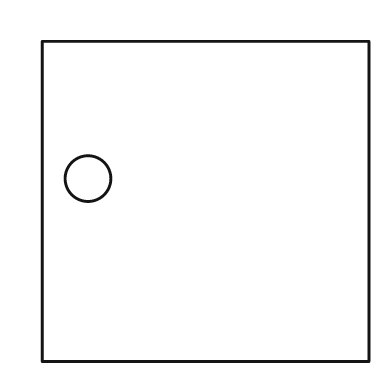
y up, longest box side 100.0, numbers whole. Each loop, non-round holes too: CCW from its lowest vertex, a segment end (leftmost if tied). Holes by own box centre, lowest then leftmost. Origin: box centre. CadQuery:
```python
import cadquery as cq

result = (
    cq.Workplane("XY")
    .moveTo(-50.0, -49.0)
    .lineTo(50.0, -49.0)
    .lineTo(50.0, 49.0)
    .lineTo(-50.0, 49.0)
    .close()
    .moveTo(-36.0, 7.0)
    .circle(7.0)
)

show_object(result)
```